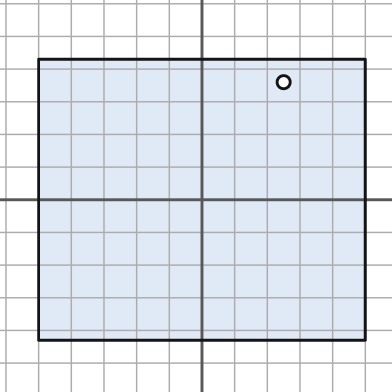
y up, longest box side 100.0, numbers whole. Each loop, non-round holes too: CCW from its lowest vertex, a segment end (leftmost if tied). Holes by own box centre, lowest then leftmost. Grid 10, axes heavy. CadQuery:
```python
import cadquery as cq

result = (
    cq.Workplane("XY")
    .moveTo(-50.0, -43.0)
    .lineTo(50.0, -43.0)
    .lineTo(50.0, 43.0)
    .lineTo(-50.0, 43.0)
    .close()
    .moveTo(25.0, 36.0)
    .circle(2.0)
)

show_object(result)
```